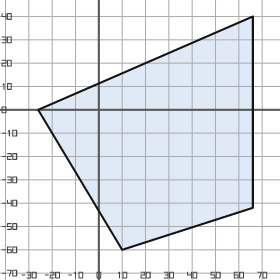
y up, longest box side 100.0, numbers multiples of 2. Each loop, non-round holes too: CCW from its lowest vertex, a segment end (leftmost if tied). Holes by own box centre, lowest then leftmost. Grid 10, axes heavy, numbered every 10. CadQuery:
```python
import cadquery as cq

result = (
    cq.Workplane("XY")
    .moveTo(10.0, -60.0)
    .lineTo(66.0, -42.0)
    .lineTo(66.0, 40.0)
    .lineTo(-26.0, 0.0)
    .close()
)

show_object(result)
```